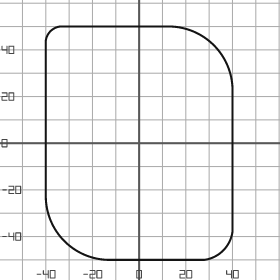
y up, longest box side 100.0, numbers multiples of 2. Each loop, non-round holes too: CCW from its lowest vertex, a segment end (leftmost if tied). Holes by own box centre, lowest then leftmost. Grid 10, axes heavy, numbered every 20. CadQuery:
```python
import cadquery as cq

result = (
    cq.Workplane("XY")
    .moveTo(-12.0, -50.0)
    .lineTo(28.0, -50.0)
    .threePointArc((36.0, -46.0), (40.0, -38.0))
    .lineTo(40.0, 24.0)
    .threePointArc((32.0, 42.0), (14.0, 50.0))
    .lineTo(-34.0, 50.0)
    .threePointArc((-38.0, 48.0), (-40.0, 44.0))
    .lineTo(-40.0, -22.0)
    .threePointArc((-32.0, -42.0), (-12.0, -50.0))
    .close()
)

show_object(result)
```